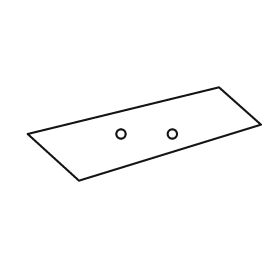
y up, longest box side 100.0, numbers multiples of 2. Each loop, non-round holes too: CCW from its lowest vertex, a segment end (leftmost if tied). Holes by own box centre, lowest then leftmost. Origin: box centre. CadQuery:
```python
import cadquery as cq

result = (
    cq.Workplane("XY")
    .moveTo(-28.0, -20.0)
    .lineTo(50.0, 4.0)
    .lineTo(32.0, 20.0)
    .lineTo(-50.0, 0.0)
    .close()
    .moveTo(-10.0, 0.0)
    .circle(2.0)
    .moveTo(12.0, 0.0)
    .circle(2.0)
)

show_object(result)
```